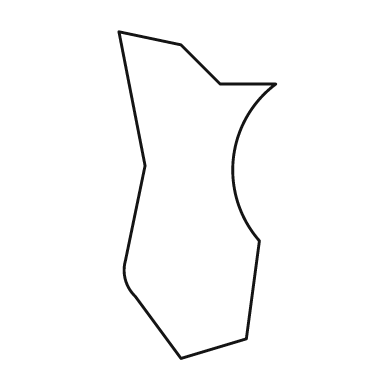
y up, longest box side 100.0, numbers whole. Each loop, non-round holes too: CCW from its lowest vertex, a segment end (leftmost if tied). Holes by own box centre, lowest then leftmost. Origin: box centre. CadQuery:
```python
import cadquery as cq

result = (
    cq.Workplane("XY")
    .moveTo(-5.0, -50.0)
    .lineTo(15.0, -44.0)
    .lineTo(19.0, -14.0)
    .threePointArc((11.0, 11.0), (24.0, 34.0))
    .lineTo(7.0, 34.0)
    .lineTo(-5.0, 46.0)
    .lineTo(-24.0, 50.0)
    .lineTo(-16.0, 9.0)
    .lineTo(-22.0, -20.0)
    .threePointArc((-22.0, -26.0), (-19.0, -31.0))
    .close()
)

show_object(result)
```